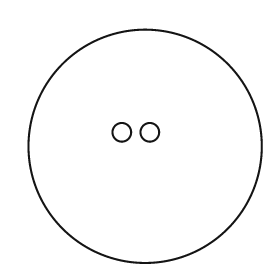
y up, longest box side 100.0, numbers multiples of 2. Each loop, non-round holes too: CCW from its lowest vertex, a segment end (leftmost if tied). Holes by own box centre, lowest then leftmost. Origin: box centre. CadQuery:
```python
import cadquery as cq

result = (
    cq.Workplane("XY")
    .moveTo(0.0, 0.0)
    .circle(50.0)
    .moveTo(-10.0, 6.0)
    .circle(4.0)
    .moveTo(2.0, 6.0)
    .circle(4.0)
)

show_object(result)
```